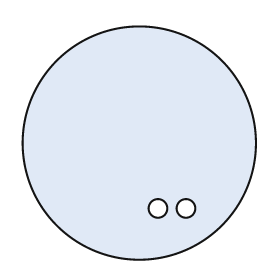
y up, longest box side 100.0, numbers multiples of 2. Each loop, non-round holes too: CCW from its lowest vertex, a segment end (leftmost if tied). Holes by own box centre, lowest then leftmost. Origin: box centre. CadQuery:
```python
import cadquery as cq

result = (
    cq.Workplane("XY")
    .moveTo(0.0, 0.0)
    .circle(50.0)
    .moveTo(8.0, -28.0)
    .circle(4.0)
    .moveTo(20.0, -28.0)
    .circle(4.0)
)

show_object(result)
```